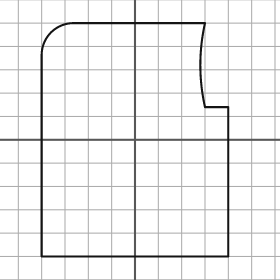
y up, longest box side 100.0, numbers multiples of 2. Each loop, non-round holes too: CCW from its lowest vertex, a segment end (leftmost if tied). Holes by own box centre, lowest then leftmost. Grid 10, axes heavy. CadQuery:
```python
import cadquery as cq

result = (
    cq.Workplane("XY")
    .moveTo(-40.0, -50.0)
    .lineTo(40.0, -50.0)
    .lineTo(40.0, 14.0)
    .lineTo(30.0, 14.0)
    .threePointArc((28.0, 32.0), (30.0, 50.0))
    .lineTo(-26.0, 50.0)
    .threePointArc((-36.0, 46.0), (-40.0, 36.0))
    .close()
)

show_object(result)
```